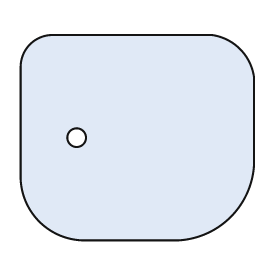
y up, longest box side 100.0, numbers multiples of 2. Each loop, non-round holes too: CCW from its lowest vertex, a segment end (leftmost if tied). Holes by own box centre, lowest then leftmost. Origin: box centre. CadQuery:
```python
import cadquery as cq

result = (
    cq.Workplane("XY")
    .moveTo(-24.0, -44.0)
    .lineTo(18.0, -44.0)
    .threePointArc((40.0, -34.0), (50.0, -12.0))
    .lineTo(50.0, 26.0)
    .threePointArc((44.0, 38.0), (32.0, 44.0))
    .lineTo(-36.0, 44.0)
    .threePointArc((-46.0, 40.0), (-50.0, 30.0))
    .lineTo(-50.0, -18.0)
    .threePointArc((-42.0, -36.0), (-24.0, -44.0))
    .close()
    .moveTo(-26.0, 0.0)
    .circle(4.0)
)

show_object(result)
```